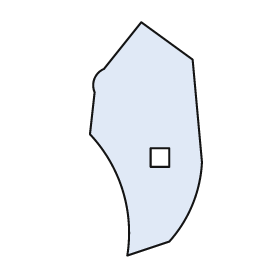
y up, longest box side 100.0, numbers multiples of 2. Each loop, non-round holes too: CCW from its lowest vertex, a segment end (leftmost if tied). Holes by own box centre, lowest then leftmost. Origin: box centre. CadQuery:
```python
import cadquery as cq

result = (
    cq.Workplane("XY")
    .moveTo(-8.0, -50.0)
    .lineTo(10.0, -44.0)
    .threePointArc((20.0, -28.0), (24.0, -10.0))
    .lineTo(20.0, 34.0)
    .lineTo(-2.0, 50.0)
    .lineTo(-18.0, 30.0)
    .threePointArc((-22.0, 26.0), (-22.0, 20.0))
    .lineTo(-24.0, 2.0)
    .threePointArc((-10.0, -22.0), (-8.0, -50.0))
    .close()
    .moveTo(2.0, -12.0)
    .lineTo(10.0, -12.0)
    .lineTo(10.0, -4.0)
    .lineTo(2.0, -4.0)
    .close()
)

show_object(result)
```